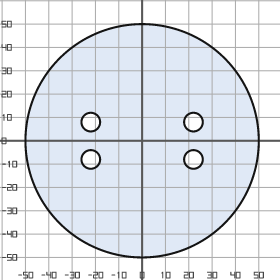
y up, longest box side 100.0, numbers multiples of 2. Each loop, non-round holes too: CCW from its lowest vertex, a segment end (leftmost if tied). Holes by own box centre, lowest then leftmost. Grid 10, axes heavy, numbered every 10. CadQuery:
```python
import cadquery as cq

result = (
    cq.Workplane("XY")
    .moveTo(0.0, 0.0)
    .circle(50.0)
    .moveTo(-22.0, -8.0)
    .circle(4.0)
    .moveTo(22.0, -8.0)
    .circle(4.0)
    .moveTo(-22.0, 8.0)
    .circle(4.0)
    .moveTo(22.0, 8.0)
    .circle(4.0)
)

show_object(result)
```